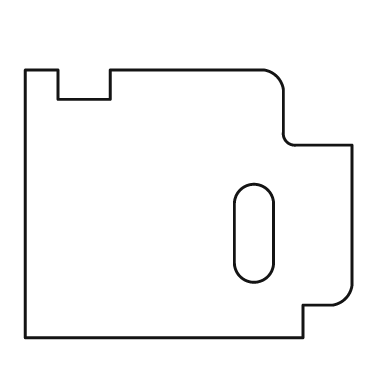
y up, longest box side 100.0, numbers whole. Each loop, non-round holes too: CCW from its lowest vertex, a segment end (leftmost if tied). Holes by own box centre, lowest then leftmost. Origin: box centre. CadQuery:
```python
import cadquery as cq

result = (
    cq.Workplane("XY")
    .moveTo(-50.0, -41.0)
    .lineTo(35.0, -41.0)
    .lineTo(35.0, -31.0)
    .lineTo(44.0, -31.0)
    .threePointArc((48.0, -29.0), (50.0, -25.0))
    .lineTo(50.0, 18.0)
    .lineTo(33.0, 18.0)
    .threePointArc((30.0, 19.0), (29.0, 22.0))
    .lineTo(29.0, 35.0)
    .threePointArc((27.0, 39.0), (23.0, 41.0))
    .lineTo(-24.0, 41.0)
    .lineTo(-24.0, 32.0)
    .lineTo(-40.0, 32.0)
    .lineTo(-40.0, 41.0)
    .lineTo(-50.0, 41.0)
    .close()
    .moveTo(14.0, -18.0)
    .threePointArc((20.0, -24.0), (26.0, -18.0))
    .lineTo(26.0, 0.0)
    .threePointArc((20.0, 6.0), (14.0, 0.0))
    .close()
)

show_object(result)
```